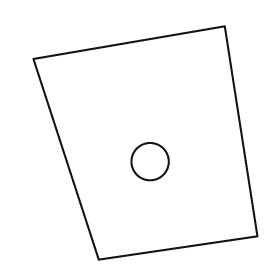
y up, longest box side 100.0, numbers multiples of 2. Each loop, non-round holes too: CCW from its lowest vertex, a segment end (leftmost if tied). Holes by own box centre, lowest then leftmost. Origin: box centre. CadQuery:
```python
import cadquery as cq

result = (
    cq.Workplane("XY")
    .moveTo(-20.0, -50.0)
    .lineTo(48.0, -40.0)
    .lineTo(34.0, 50.0)
    .lineTo(-48.0, 36.0)
    .close()
    .moveTo(2.0, -8.0)
    .circle(8.0)
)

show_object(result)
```